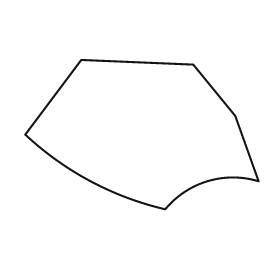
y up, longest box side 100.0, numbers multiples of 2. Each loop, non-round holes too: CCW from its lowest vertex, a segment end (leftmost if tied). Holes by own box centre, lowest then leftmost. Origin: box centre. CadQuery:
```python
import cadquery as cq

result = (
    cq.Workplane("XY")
    .moveTo(10.0, -32.0)
    .threePointArc((28.0, -20.0), (50.0, -20.0))
    .lineTo(40.0, 8.0)
    .lineTo(22.0, 30.0)
    .lineTo(-26.0, 32.0)
    .lineTo(-50.0, 0.0)
    .threePointArc((-22.0, -20.0), (10.0, -32.0))
    .close()
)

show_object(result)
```